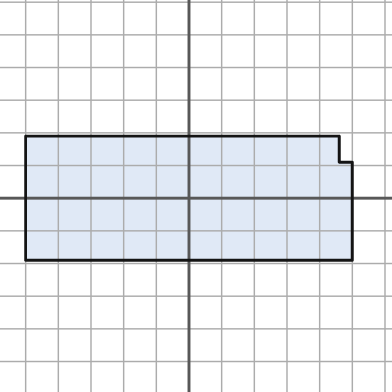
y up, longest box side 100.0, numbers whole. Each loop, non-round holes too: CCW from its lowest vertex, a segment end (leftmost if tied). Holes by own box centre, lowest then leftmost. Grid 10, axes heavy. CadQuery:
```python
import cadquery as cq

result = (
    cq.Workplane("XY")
    .moveTo(-50.0, -19.0)
    .lineTo(50.0, -19.0)
    .lineTo(50.0, 11.0)
    .lineTo(46.0, 11.0)
    .lineTo(46.0, 19.0)
    .lineTo(-50.0, 19.0)
    .close()
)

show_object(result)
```